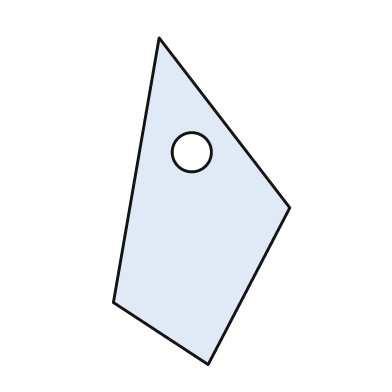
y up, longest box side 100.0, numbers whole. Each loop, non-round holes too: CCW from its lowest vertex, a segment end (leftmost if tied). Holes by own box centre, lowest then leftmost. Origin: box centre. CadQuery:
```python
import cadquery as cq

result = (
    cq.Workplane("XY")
    .moveTo(2.0, -50.0)
    .lineTo(27.0, -2.0)
    .lineTo(-13.0, 50.0)
    .lineTo(-27.0, -31.0)
    .close()
    .moveTo(-3.0, 15.0)
    .circle(6.0)
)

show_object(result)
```